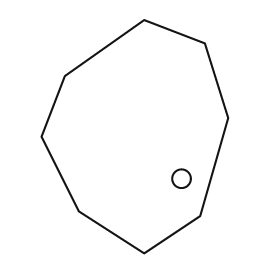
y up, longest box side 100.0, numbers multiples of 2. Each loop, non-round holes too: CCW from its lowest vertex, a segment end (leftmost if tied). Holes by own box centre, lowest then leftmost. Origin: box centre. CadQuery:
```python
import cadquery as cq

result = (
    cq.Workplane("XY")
    .moveTo(4.0, -50.0)
    .lineTo(28.0, -34.0)
    .lineTo(40.0, 8.0)
    .lineTo(30.0, 40.0)
    .lineTo(4.0, 50.0)
    .lineTo(-30.0, 26.0)
    .lineTo(-40.0, 0.0)
    .lineTo(-24.0, -32.0)
    .close()
    .moveTo(20.0, -18.0)
    .circle(4.0)
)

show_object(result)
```